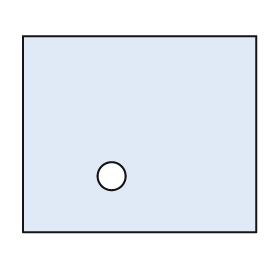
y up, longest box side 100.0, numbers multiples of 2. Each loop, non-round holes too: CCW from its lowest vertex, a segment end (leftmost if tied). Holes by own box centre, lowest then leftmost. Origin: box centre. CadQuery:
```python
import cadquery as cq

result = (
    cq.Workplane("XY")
    .moveTo(-50.0, -42.0)
    .lineTo(50.0, -42.0)
    .lineTo(50.0, 42.0)
    .lineTo(-50.0, 42.0)
    .close()
    .moveTo(-12.0, -18.0)
    .circle(6.0)
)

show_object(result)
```